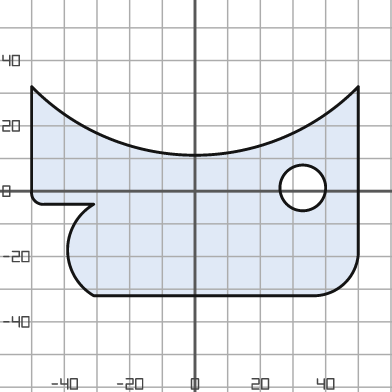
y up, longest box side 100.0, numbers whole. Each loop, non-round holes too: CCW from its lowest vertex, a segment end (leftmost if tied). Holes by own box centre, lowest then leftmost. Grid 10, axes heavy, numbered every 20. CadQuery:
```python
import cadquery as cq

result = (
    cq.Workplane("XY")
    .moveTo(-31.0, -32.0)
    .lineTo(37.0, -32.0)
    .threePointArc((46.0, -28.0), (50.0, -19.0))
    .lineTo(50.0, 32.0)
    .threePointArc((0.0, 11.0), (-50.0, 32.0))
    .lineTo(-50.0, 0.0)
    .threePointArc((-49.0, -3.0), (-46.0, -4.0))
    .lineTo(-31.0, -4.0)
    .threePointArc((-39.0, -18.0), (-31.0, -32.0))
    .close()
    .moveTo(33.0, 1.0)
    .circle(7.0)
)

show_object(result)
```